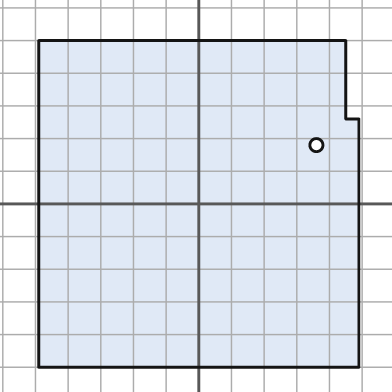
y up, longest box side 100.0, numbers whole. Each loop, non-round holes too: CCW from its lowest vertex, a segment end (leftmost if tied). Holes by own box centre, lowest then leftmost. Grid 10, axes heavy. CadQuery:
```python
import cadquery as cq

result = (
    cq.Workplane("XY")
    .moveTo(-49.0, -50.0)
    .lineTo(49.0, -50.0)
    .lineTo(49.0, 26.0)
    .lineTo(45.0, 26.0)
    .lineTo(45.0, 50.0)
    .lineTo(-49.0, 50.0)
    .close()
    .moveTo(36.0, 18.0)
    .circle(2.0)
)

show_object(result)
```